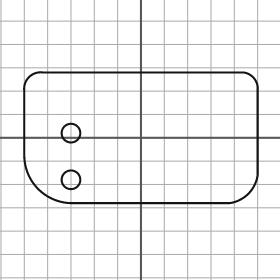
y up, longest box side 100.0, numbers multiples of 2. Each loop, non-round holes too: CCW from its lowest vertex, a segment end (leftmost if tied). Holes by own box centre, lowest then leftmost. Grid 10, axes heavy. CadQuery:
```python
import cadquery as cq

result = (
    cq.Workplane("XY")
    .moveTo(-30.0, -28.0)
    .lineTo(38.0, -28.0)
    .threePointArc((46.0, -24.0), (50.0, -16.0))
    .lineTo(50.0, 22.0)
    .threePointArc((48.0, 26.0), (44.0, 28.0))
    .lineTo(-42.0, 28.0)
    .threePointArc((-48.0, 26.0), (-50.0, 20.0))
    .lineTo(-50.0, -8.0)
    .threePointArc((-44.0, -22.0), (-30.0, -28.0))
    .close()
    .moveTo(-30.0, -18.0)
    .circle(4.0)
    .moveTo(-30.0, 2.0)
    .circle(4.0)
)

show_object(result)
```